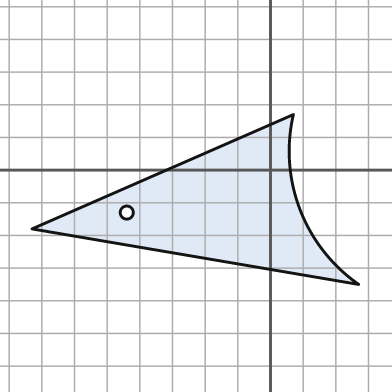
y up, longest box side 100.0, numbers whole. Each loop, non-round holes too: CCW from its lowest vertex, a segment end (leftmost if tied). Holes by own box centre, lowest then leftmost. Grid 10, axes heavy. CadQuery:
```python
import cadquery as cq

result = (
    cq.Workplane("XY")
    .moveTo(27.0, -35.0)
    .threePointArc((9.0, -12.0), (7.0, 17.0))
    .lineTo(-73.0, -18.0)
    .close()
    .moveTo(-44.0, -13.0)
    .circle(2.0)
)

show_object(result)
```